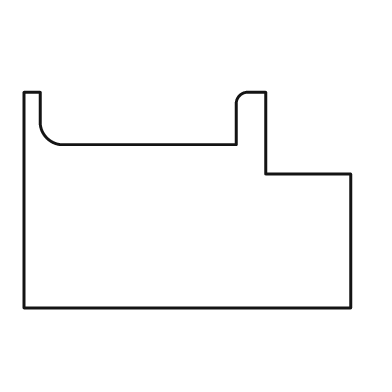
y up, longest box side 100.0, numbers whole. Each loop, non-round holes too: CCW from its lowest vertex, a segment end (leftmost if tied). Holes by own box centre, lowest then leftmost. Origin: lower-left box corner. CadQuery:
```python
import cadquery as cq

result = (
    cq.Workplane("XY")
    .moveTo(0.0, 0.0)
    .lineTo(100.0, 0.0)
    .lineTo(100.0, 41.0)
    .lineTo(74.0, 41.0)
    .lineTo(74.0, 66.0)
    .lineTo(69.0, 66.0)
    .threePointArc((66.0, 65.0), (65.0, 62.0))
    .lineTo(65.0, 50.0)
    .lineTo(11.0, 50.0)
    .threePointArc((7.0, 52.0), (5.0, 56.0))
    .lineTo(5.0, 66.0)
    .lineTo(0.0, 66.0)
    .close()
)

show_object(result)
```